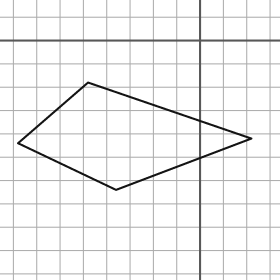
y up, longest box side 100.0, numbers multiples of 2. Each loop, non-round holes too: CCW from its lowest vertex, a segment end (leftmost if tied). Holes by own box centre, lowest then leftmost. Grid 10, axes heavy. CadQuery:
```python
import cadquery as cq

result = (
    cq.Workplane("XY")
    .moveTo(-36.0, -64.0)
    .lineTo(22.0, -42.0)
    .lineTo(-48.0, -18.0)
    .lineTo(-78.0, -44.0)
    .close()
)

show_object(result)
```